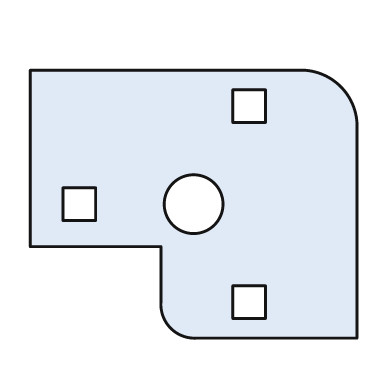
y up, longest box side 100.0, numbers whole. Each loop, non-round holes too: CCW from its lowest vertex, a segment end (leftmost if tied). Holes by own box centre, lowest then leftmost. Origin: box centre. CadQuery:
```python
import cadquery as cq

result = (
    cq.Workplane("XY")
    .moveTo(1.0, -41.0)
    .lineTo(50.0, -41.0)
    .lineTo(50.0, 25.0)
    .threePointArc((45.0, 36.0), (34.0, 41.0))
    .lineTo(-50.0, 41.0)
    .lineTo(-50.0, -13.0)
    .lineTo(-10.0, -13.0)
    .lineTo(-10.0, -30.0)
    .threePointArc((-7.0, -38.0), (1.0, -41.0))
    .close()
    .moveTo(12.0, -35.0)
    .lineTo(22.0, -35.0)
    .lineTo(22.0, -25.0)
    .lineTo(12.0, -25.0)
    .close()
    .moveTo(-40.0, -5.0)
    .lineTo(-30.0, -5.0)
    .lineTo(-30.0, 5.0)
    .lineTo(-40.0, 5.0)
    .close()
    .moveTo(0.0, 0.0)
    .circle(9.0)
    .moveTo(12.0, 25.0)
    .lineTo(22.0, 25.0)
    .lineTo(22.0, 35.0)
    .lineTo(12.0, 35.0)
    .close()
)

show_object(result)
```